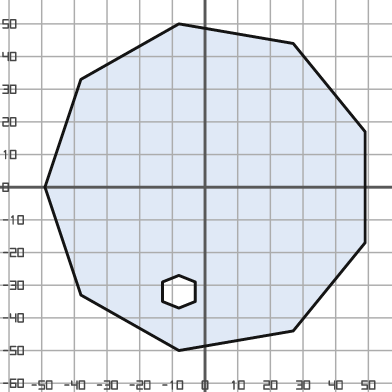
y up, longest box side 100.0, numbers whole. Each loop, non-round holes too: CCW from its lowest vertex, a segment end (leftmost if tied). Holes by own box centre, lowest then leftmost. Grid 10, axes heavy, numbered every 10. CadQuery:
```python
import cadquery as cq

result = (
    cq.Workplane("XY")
    .moveTo(-8.0, -50.0)
    .lineTo(27.0, -44.0)
    .lineTo(49.0, -17.0)
    .lineTo(49.0, 17.0)
    .lineTo(27.0, 44.0)
    .lineTo(-8.0, 50.0)
    .lineTo(-38.0, 33.0)
    .lineTo(-49.0, 0.0)
    .lineTo(-38.0, -33.0)
    .close()
    .moveTo(-8.0, -37.0)
    .lineTo(-3.0, -35.0)
    .lineTo(-3.0, -29.0)
    .lineTo(-8.0, -27.0)
    .lineTo(-13.0, -29.0)
    .lineTo(-13.0, -35.0)
    .close()
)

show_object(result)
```